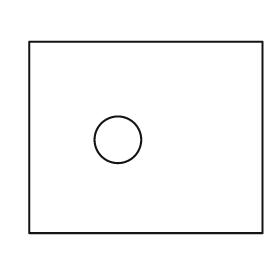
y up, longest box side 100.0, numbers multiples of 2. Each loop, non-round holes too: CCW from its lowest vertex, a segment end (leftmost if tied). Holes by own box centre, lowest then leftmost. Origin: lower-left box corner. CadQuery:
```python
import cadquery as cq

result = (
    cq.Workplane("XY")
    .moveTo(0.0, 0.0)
    .lineTo(100.0, 0.0)
    .lineTo(100.0, 82.0)
    .lineTo(0.0, 82.0)
    .close()
    .moveTo(38.0, 40.0)
    .circle(10.0)
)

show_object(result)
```